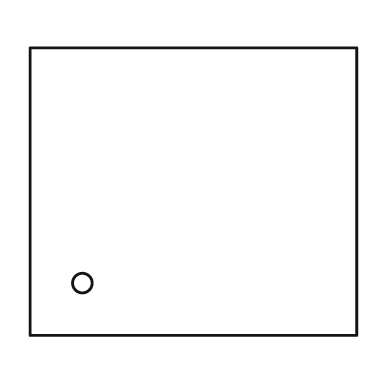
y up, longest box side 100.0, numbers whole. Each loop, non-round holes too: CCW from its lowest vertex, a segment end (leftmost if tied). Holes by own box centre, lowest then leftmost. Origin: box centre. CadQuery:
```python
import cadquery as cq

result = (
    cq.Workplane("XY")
    .moveTo(-50.0, -44.0)
    .lineTo(50.0, -44.0)
    .lineTo(50.0, 44.0)
    .lineTo(-50.0, 44.0)
    .close()
    .moveTo(-34.0, -28.0)
    .circle(3.0)
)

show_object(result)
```